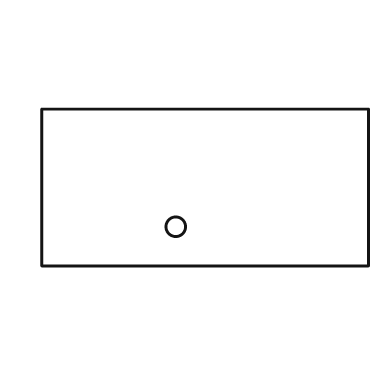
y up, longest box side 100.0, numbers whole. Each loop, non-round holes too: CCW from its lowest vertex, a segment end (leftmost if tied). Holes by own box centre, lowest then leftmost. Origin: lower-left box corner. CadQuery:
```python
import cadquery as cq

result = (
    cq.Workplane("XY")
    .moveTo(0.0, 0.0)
    .lineTo(100.0, 0.0)
    .lineTo(100.0, 48.0)
    .lineTo(0.0, 48.0)
    .close()
    .moveTo(41.0, 12.0)
    .circle(3.0)
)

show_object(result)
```